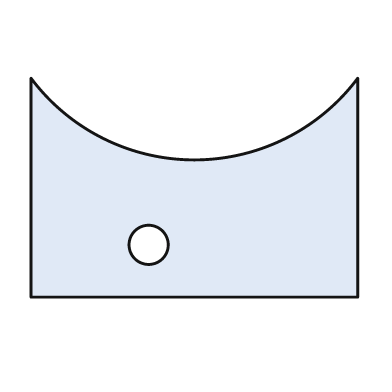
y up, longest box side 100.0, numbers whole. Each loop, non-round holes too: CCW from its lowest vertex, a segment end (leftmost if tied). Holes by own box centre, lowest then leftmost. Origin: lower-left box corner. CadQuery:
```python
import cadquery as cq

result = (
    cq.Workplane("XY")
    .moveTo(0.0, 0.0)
    .lineTo(100.0, 0.0)
    .lineTo(100.0, 67.0)
    .threePointArc((50.0, 42.0), (0.0, 67.0))
    .close()
    .moveTo(36.0, 16.0)
    .circle(6.0)
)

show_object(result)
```